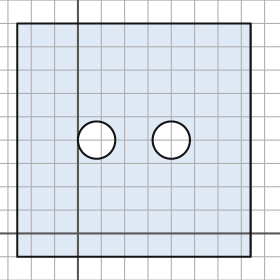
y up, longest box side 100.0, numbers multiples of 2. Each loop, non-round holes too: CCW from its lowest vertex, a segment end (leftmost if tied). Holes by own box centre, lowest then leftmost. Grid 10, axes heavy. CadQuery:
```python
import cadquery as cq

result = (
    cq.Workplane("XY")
    .moveTo(-26.0, -10.0)
    .lineTo(74.0, -10.0)
    .lineTo(74.0, 90.0)
    .lineTo(-26.0, 90.0)
    .close()
    .moveTo(8.0, 40.0)
    .circle(8.0)
    .moveTo(40.0, 40.0)
    .circle(8.0)
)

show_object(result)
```